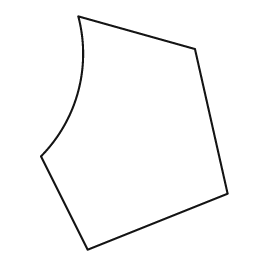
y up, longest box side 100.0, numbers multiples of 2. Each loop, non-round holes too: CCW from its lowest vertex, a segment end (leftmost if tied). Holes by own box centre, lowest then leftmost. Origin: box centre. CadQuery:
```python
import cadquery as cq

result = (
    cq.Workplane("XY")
    .moveTo(-20.0, -50.0)
    .lineTo(40.0, -26.0)
    .lineTo(26.0, 36.0)
    .lineTo(-24.0, 50.0)
    .threePointArc((-24.0, 18.0), (-40.0, -10.0))
    .close()
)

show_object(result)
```